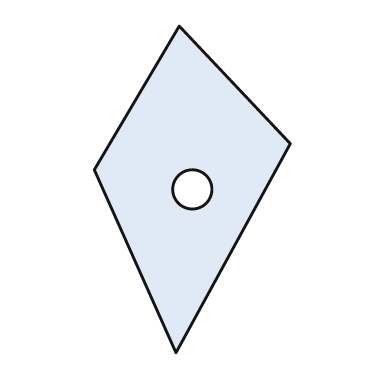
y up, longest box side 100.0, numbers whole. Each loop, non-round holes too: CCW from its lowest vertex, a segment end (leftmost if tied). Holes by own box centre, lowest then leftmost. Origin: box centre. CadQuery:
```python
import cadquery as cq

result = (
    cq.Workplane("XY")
    .moveTo(-5.0, -50.0)
    .lineTo(30.0, 14.0)
    .lineTo(-4.0, 50.0)
    .lineTo(-30.0, 6.0)
    .close()
    .moveTo(0.0, 0.0)
    .circle(6.0)
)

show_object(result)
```